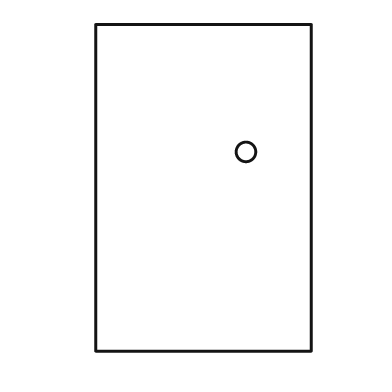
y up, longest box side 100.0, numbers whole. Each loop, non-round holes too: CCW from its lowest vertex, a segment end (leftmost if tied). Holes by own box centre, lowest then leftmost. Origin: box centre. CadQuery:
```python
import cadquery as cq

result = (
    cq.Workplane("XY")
    .moveTo(-33.0, -50.0)
    .lineTo(33.0, -50.0)
    .lineTo(33.0, 50.0)
    .lineTo(-33.0, 50.0)
    .close()
    .moveTo(13.0, 11.0)
    .circle(3.0)
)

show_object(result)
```